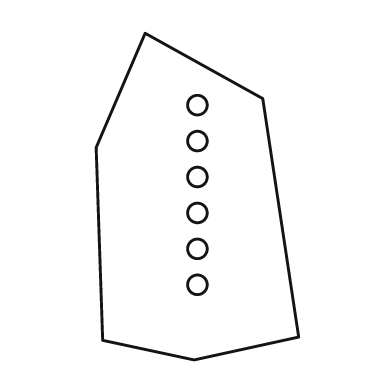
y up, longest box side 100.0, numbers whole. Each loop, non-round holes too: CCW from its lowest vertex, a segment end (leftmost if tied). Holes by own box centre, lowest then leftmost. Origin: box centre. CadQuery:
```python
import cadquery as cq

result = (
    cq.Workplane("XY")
    .moveTo(-1.0, -50.0)
    .lineTo(31.0, -43.0)
    .lineTo(20.0, 30.0)
    .lineTo(-16.0, 50.0)
    .lineTo(-31.0, 15.0)
    .lineTo(-29.0, -44.0)
    .close()
    .moveTo(0.0, -27.0)
    .circle(3.0)
    .moveTo(0.0, -16.0)
    .circle(3.0)
    .moveTo(0.0, -5.0)
    .circle(3.0)
    .moveTo(0.0, 6.0)
    .circle(3.0)
    .moveTo(0.0, 17.0)
    .circle(3.0)
    .moveTo(0.0, 28.0)
    .circle(3.0)
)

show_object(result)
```